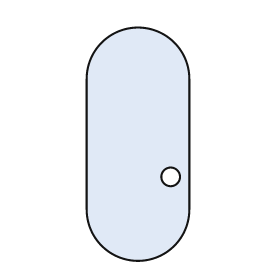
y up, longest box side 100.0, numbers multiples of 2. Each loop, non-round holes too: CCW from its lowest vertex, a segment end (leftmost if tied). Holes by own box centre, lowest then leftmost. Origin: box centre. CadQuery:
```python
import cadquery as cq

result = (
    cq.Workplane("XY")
    .moveTo(-22.0, -28.0)
    .threePointArc((0.0, -50.0), (22.0, -28.0))
    .lineTo(22.0, 28.0)
    .threePointArc((0.0, 50.0), (-22.0, 28.0))
    .close()
    .moveTo(14.0, -14.0)
    .circle(4.0)
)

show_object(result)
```